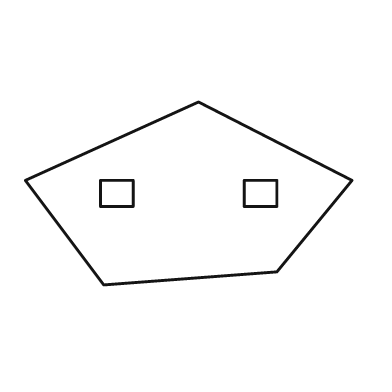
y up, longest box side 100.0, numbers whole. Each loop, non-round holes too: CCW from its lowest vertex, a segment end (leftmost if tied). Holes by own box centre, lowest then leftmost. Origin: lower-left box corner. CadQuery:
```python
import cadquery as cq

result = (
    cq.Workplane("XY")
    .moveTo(24.0, 0.0)
    .lineTo(77.0, 4.0)
    .lineTo(100.0, 32.0)
    .lineTo(53.0, 56.0)
    .lineTo(0.0, 32.0)
    .close()
    .moveTo(23.0, 24.0)
    .lineTo(33.0, 24.0)
    .lineTo(33.0, 32.0)
    .lineTo(23.0, 32.0)
    .close()
    .moveTo(67.0, 24.0)
    .lineTo(77.0, 24.0)
    .lineTo(77.0, 32.0)
    .lineTo(67.0, 32.0)
    .close()
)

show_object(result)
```